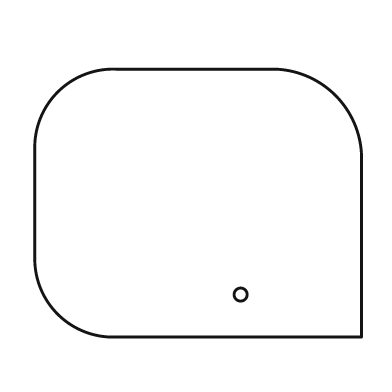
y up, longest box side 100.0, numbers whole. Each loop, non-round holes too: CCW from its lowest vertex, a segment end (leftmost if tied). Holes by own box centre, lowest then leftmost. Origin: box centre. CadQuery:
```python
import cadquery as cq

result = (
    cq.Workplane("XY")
    .moveTo(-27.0, -41.0)
    .lineTo(50.0, -41.0)
    .lineTo(50.0, 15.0)
    .threePointArc((42.0, 33.0), (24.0, 41.0))
    .lineTo(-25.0, 41.0)
    .threePointArc((-43.0, 34.0), (-50.0, 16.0))
    .lineTo(-50.0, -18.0)
    .threePointArc((-43.0, -34.0), (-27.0, -41.0))
    .close()
    .moveTo(13.0, -28.0)
    .circle(2.0)
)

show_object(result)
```